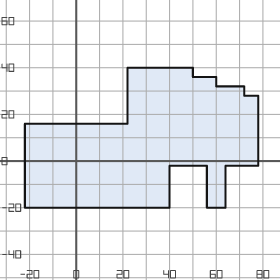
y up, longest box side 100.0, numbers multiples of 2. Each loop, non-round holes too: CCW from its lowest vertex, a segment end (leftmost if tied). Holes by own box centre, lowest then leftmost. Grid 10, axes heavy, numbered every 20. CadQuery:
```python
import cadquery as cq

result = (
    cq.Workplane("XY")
    .moveTo(-22.0, -20.0)
    .lineTo(40.0, -20.0)
    .lineTo(40.0, -2.0)
    .lineTo(56.0, -2.0)
    .lineTo(56.0, -20.0)
    .lineTo(64.0, -20.0)
    .lineTo(64.0, -2.0)
    .lineTo(78.0, -2.0)
    .lineTo(78.0, 28.0)
    .lineTo(72.0, 28.0)
    .lineTo(72.0, 32.0)
    .lineTo(60.0, 32.0)
    .lineTo(60.0, 36.0)
    .lineTo(50.0, 36.0)
    .lineTo(50.0, 40.0)
    .lineTo(22.0, 40.0)
    .lineTo(22.0, 16.0)
    .lineTo(-22.0, 16.0)
    .close()
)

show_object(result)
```